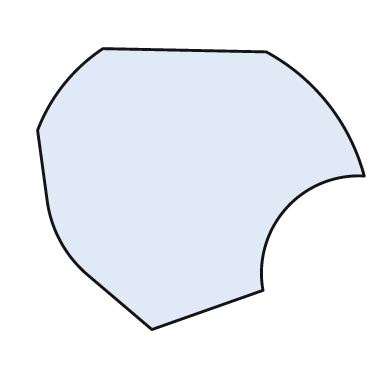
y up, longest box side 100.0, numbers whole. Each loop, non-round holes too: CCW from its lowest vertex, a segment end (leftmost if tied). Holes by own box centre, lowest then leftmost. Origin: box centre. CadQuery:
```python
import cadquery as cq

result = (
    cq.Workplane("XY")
    .moveTo(-15.0, -43.0)
    .lineTo(19.0, -31.0)
    .threePointArc((26.0, -6.0), (50.0, 4.0))
    .threePointArc((39.0, 26.0), (20.0, 42.0))
    .lineTo(-30.0, 43.0)
    .threePointArc((-42.0, 32.0), (-50.0, 18.0))
    .lineTo(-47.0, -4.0)
    .threePointArc((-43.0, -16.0), (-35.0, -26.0))
    .close()
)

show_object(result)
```